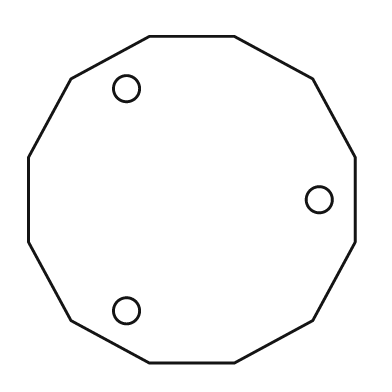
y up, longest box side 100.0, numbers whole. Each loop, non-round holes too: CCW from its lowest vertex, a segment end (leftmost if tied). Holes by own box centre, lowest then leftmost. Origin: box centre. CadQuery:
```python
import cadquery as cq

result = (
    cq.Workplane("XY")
    .moveTo(-13.0, -50.0)
    .lineTo(13.0, -50.0)
    .lineTo(37.0, -37.0)
    .lineTo(50.0, -13.0)
    .lineTo(50.0, 13.0)
    .lineTo(37.0, 37.0)
    .lineTo(13.0, 50.0)
    .lineTo(-13.0, 50.0)
    .lineTo(-37.0, 37.0)
    .lineTo(-50.0, 13.0)
    .lineTo(-50.0, -13.0)
    .lineTo(-37.0, -37.0)
    .close()
    .moveTo(-20.0, -34.0)
    .circle(4.0)
    .moveTo(39.0, 0.0)
    .circle(4.0)
    .moveTo(-20.0, 34.0)
    .circle(4.0)
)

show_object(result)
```